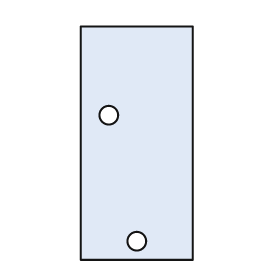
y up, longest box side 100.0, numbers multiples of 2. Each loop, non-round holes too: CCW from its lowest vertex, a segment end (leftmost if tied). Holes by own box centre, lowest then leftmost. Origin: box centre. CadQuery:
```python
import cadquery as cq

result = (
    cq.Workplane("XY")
    .moveTo(-24.0, -50.0)
    .lineTo(24.0, -50.0)
    .lineTo(24.0, 50.0)
    .lineTo(-24.0, 50.0)
    .close()
    .moveTo(0.0, -42.0)
    .circle(4.0)
    .moveTo(-12.0, 12.0)
    .circle(4.0)
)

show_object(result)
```